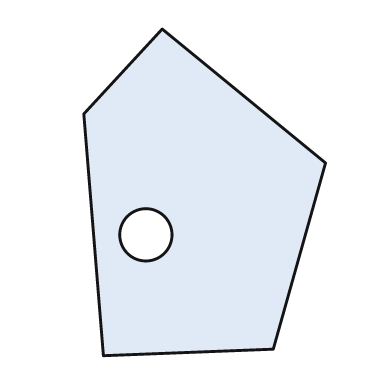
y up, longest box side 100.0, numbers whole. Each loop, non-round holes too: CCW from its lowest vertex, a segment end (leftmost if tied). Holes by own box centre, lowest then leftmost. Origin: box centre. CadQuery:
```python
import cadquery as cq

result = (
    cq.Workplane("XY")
    .moveTo(-31.0, -50.0)
    .lineTo(21.0, -48.0)
    .lineTo(37.0, 9.0)
    .lineTo(-13.0, 50.0)
    .lineTo(-37.0, 24.0)
    .close()
    .moveTo(-18.0, -13.0)
    .circle(8.0)
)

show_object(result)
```